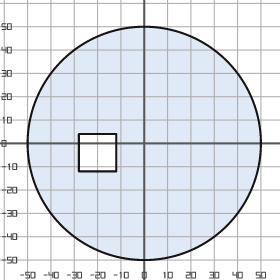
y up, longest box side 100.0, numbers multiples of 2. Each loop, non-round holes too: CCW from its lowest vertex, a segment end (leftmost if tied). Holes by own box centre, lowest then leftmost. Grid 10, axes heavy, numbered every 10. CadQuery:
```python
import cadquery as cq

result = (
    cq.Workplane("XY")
    .moveTo(0.0, 0.0)
    .circle(50.0)
    .moveTo(-28.0, -12.0)
    .lineTo(-12.0, -12.0)
    .lineTo(-12.0, 4.0)
    .lineTo(-28.0, 4.0)
    .close()
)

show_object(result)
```